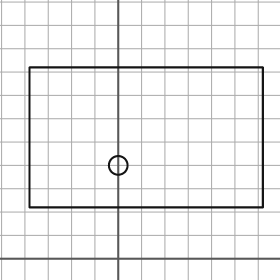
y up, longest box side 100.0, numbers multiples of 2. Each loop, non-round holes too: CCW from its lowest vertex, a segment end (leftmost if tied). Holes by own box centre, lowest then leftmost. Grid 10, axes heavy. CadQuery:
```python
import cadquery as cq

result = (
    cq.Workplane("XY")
    .moveTo(-38.0, 22.0)
    .lineTo(62.0, 22.0)
    .lineTo(62.0, 82.0)
    .lineTo(-38.0, 82.0)
    .close()
    .moveTo(0.0, 40.0)
    .circle(4.0)
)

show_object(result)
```